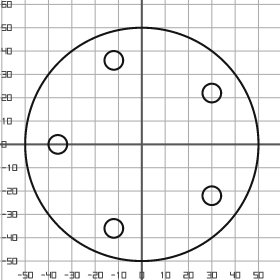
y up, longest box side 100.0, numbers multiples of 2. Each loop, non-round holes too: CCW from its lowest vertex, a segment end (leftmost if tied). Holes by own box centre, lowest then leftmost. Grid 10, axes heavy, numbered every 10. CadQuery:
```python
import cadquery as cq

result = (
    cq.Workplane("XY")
    .moveTo(0.0, 0.0)
    .circle(50.0)
    .moveTo(-12.0, -36.0)
    .circle(4.0)
    .moveTo(30.0, -22.0)
    .circle(4.0)
    .moveTo(-36.0, 0.0)
    .circle(4.0)
    .moveTo(30.0, 22.0)
    .circle(4.0)
    .moveTo(-12.0, 36.0)
    .circle(4.0)
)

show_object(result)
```